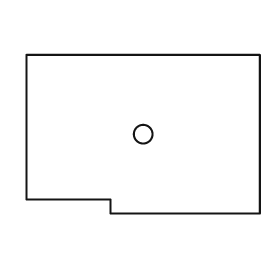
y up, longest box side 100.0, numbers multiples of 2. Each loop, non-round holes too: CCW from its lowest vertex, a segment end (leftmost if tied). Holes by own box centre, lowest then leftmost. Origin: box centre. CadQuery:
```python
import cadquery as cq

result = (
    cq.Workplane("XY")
    .moveTo(-14.0, -34.0)
    .lineTo(50.0, -34.0)
    .lineTo(50.0, 34.0)
    .lineTo(-50.0, 34.0)
    .lineTo(-50.0, -28.0)
    .lineTo(-14.0, -28.0)
    .close()
    .moveTo(0.0, 0.0)
    .circle(4.0)
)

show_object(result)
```